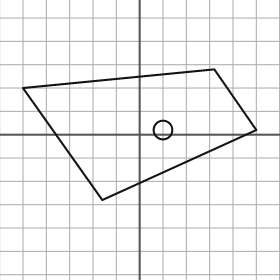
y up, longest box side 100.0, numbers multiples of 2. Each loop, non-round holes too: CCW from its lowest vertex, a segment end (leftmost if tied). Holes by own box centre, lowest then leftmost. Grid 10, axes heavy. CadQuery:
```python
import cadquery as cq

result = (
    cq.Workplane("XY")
    .moveTo(-16.0, -28.0)
    .lineTo(50.0, 2.0)
    .lineTo(32.0, 28.0)
    .lineTo(-50.0, 20.0)
    .close()
    .moveTo(10.0, 2.0)
    .circle(4.0)
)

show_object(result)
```